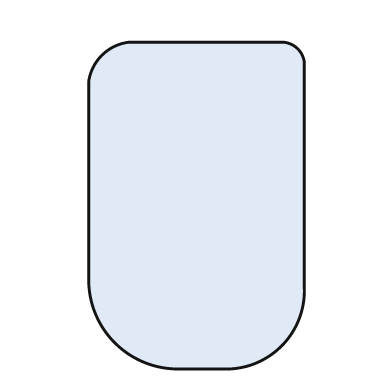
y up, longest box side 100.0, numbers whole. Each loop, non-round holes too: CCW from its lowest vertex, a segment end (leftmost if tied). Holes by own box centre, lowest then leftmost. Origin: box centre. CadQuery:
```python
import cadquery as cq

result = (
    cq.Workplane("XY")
    .moveTo(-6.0, -50.0)
    .lineTo(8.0, -50.0)
    .threePointArc((26.0, -43.0), (33.0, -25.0))
    .lineTo(33.0, 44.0)
    .threePointArc((31.0, 48.0), (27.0, 50.0))
    .lineTo(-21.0, 50.0)
    .threePointArc((-29.0, 46.0), (-33.0, 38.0))
    .lineTo(-33.0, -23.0)
    .threePointArc((-25.0, -42.0), (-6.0, -50.0))
    .close()
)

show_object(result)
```